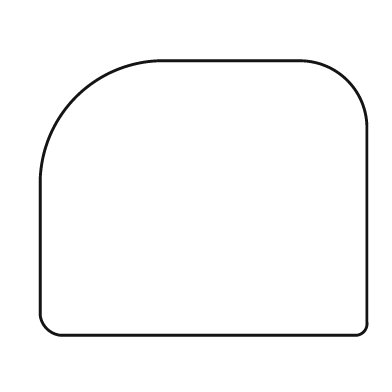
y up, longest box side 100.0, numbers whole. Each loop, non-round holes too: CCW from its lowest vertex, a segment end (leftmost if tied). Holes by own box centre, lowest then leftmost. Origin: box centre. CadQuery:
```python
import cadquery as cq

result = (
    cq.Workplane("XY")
    .moveTo(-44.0, -42.0)
    .lineTo(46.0, -42.0)
    .threePointArc((49.0, -41.0), (50.0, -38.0))
    .lineTo(50.0, 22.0)
    .threePointArc((44.0, 36.0), (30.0, 42.0))
    .lineTo(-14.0, 42.0)
    .threePointArc((-39.0, 31.0), (-50.0, 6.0))
    .lineTo(-50.0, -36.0)
    .threePointArc((-48.0, -40.0), (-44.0, -42.0))
    .close()
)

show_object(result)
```